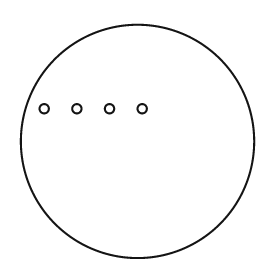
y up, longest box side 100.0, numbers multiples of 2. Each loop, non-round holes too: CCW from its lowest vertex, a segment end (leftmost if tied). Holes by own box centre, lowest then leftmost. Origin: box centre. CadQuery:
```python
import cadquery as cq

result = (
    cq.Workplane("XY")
    .moveTo(0.0, 0.0)
    .circle(50.0)
    .moveTo(-40.0, 14.0)
    .circle(2.0)
    .moveTo(-26.0, 14.0)
    .circle(2.0)
    .moveTo(-12.0, 14.0)
    .circle(2.0)
    .moveTo(2.0, 14.0)
    .circle(2.0)
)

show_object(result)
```